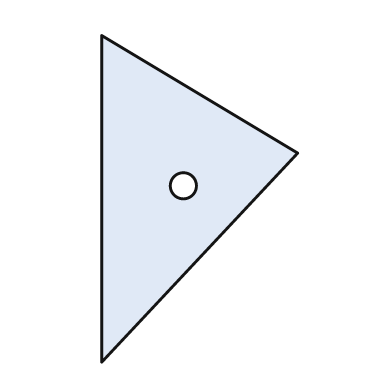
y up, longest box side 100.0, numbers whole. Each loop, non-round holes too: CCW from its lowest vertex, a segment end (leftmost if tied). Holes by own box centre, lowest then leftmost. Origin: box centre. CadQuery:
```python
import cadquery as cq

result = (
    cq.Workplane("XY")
    .moveTo(-30.0, -50.0)
    .lineTo(30.0, 14.0)
    .lineTo(-30.0, 50.0)
    .close()
    .moveTo(-5.0, 4.0)
    .circle(4.0)
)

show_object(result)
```